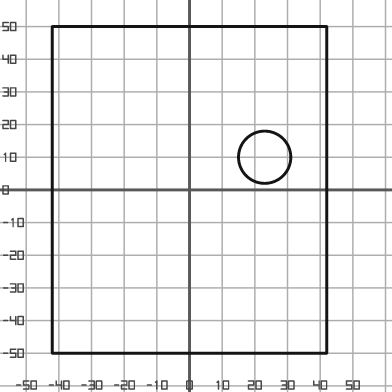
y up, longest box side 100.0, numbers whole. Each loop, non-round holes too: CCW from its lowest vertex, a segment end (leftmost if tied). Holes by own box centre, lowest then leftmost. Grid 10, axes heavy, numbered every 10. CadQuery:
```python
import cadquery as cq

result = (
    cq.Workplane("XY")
    .moveTo(-42.0, -50.0)
    .lineTo(42.0, -50.0)
    .lineTo(42.0, 50.0)
    .lineTo(-42.0, 50.0)
    .close()
    .moveTo(23.0, 10.0)
    .circle(8.0)
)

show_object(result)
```